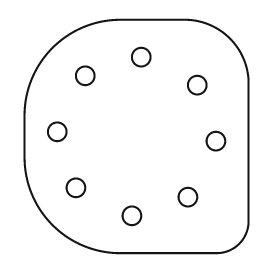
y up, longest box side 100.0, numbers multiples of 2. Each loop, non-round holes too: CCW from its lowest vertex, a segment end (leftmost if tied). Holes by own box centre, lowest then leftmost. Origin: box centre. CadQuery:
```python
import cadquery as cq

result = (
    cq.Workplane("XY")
    .moveTo(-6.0, -50.0)
    .lineTo(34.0, -50.0)
    .threePointArc((44.0, -46.0), (48.0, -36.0))
    .lineTo(48.0, 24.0)
    .threePointArc((40.0, 42.0), (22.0, 50.0))
    .lineTo(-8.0, 50.0)
    .threePointArc((-36.0, 38.0), (-48.0, 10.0))
    .lineTo(-48.0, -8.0)
    .threePointArc((-36.0, -38.0), (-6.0, -50.0))
    .close()
    .moveTo(-2.0, -34.0)
    .circle(4.0)
    .moveTo(22.0, -26.0)
    .circle(4.0)
    .moveTo(-26.0, -22.0)
    .circle(4.0)
    .moveTo(34.0, -2.0)
    .circle(4.0)
    .moveTo(-34.0, 2.0)
    .circle(4.0)
    .moveTo(26.0, 22.0)
    .circle(4.0)
    .moveTo(-22.0, 26.0)
    .circle(4.0)
    .moveTo(2.0, 34.0)
    .circle(4.0)
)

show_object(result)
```